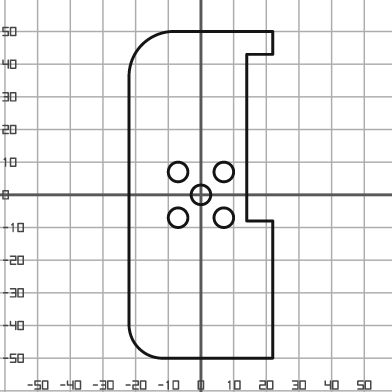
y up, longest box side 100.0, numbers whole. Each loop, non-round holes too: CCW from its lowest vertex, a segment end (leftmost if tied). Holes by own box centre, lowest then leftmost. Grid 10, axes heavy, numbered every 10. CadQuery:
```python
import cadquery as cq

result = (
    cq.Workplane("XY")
    .moveTo(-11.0, -50.0)
    .lineTo(22.0, -50.0)
    .lineTo(22.0, -8.0)
    .lineTo(14.0, -8.0)
    .lineTo(14.0, 43.0)
    .lineTo(22.0, 43.0)
    .lineTo(22.0, 50.0)
    .lineTo(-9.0, 50.0)
    .threePointArc((-18.0, 46.0), (-22.0, 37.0))
    .lineTo(-22.0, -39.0)
    .threePointArc((-19.0, -47.0), (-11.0, -50.0))
    .close()
    .moveTo(-7.0, -7.0)
    .circle(3.0)
    .moveTo(7.0, -7.0)
    .circle(3.0)
    .moveTo(0.0, 0.0)
    .circle(3.0)
    .moveTo(-7.0, 7.0)
    .circle(3.0)
    .moveTo(7.0, 7.0)
    .circle(3.0)
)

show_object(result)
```